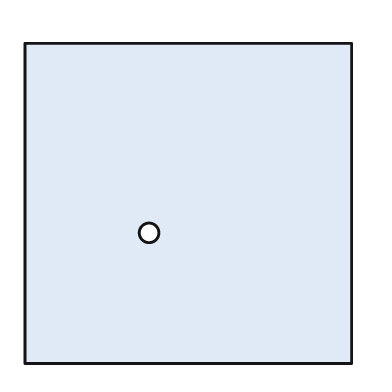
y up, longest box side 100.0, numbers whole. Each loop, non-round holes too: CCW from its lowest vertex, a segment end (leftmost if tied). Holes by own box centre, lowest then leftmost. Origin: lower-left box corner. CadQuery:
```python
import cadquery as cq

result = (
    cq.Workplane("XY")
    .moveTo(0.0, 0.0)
    .lineTo(100.0, 0.0)
    .lineTo(100.0, 98.0)
    .lineTo(0.0, 98.0)
    .close()
    .moveTo(38.0, 40.0)
    .circle(3.0)
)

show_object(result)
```